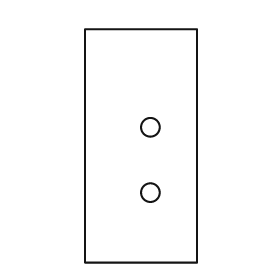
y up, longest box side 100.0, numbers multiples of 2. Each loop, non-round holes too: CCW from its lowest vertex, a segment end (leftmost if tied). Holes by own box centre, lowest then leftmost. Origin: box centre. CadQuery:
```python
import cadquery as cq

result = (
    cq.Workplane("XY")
    .moveTo(-24.0, -50.0)
    .lineTo(24.0, -50.0)
    .lineTo(24.0, 50.0)
    .lineTo(-24.0, 50.0)
    .close()
    .moveTo(4.0, -20.0)
    .circle(4.0)
    .moveTo(4.0, 8.0)
    .circle(4.0)
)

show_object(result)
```